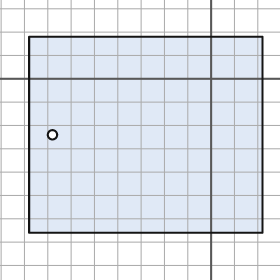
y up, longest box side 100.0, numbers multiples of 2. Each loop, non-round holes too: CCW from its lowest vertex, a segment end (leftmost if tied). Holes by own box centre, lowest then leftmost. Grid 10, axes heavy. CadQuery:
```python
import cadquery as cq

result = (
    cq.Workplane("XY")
    .moveTo(-78.0, -66.0)
    .lineTo(22.0, -66.0)
    .lineTo(22.0, 18.0)
    .lineTo(-78.0, 18.0)
    .close()
    .moveTo(-68.0, -24.0)
    .circle(2.0)
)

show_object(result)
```